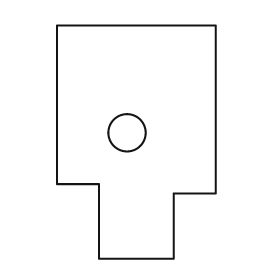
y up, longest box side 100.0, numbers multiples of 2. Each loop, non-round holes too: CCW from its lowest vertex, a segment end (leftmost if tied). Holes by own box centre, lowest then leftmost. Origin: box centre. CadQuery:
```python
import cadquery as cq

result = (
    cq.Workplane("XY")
    .moveTo(-16.0, -50.0)
    .lineTo(16.0, -50.0)
    .lineTo(16.0, -22.0)
    .lineTo(34.0, -22.0)
    .lineTo(34.0, 50.0)
    .lineTo(-34.0, 50.0)
    .lineTo(-34.0, -18.0)
    .lineTo(-16.0, -18.0)
    .close()
    .moveTo(-4.0, 4.0)
    .circle(8.0)
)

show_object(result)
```